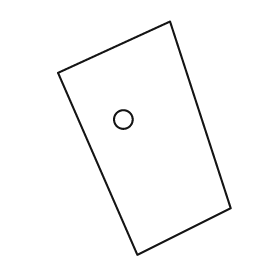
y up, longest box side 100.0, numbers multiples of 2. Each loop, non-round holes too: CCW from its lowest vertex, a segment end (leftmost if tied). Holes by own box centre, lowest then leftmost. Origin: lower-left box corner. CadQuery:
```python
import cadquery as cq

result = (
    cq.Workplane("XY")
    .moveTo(34.0, 0.0)
    .lineTo(74.0, 20.0)
    .lineTo(48.0, 100.0)
    .lineTo(0.0, 78.0)
    .close()
    .moveTo(28.0, 58.0)
    .circle(4.0)
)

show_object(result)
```